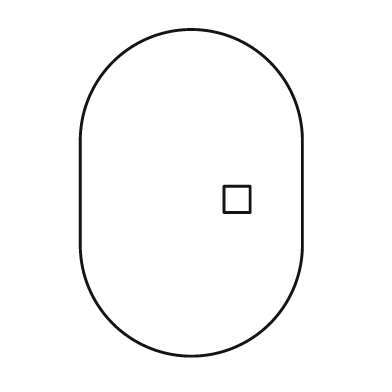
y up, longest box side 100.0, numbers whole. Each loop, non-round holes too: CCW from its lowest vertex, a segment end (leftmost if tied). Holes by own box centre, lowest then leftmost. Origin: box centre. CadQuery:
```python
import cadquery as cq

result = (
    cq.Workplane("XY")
    .moveTo(-34.0, -16.0)
    .threePointArc((0.0, -50.0), (34.0, -16.0))
    .lineTo(34.0, 16.0)
    .threePointArc((0.0, 50.0), (-34.0, 16.0))
    .close()
    .moveTo(10.0, -6.0)
    .lineTo(18.0, -6.0)
    .lineTo(18.0, 2.0)
    .lineTo(10.0, 2.0)
    .close()
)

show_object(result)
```